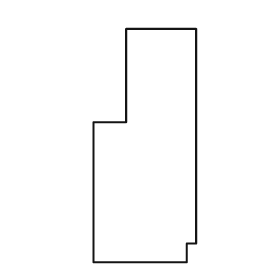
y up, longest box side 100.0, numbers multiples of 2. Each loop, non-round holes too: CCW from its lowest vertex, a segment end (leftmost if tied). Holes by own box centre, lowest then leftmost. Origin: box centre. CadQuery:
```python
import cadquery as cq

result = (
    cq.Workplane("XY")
    .moveTo(-22.0, -50.0)
    .lineTo(18.0, -50.0)
    .lineTo(18.0, -42.0)
    .lineTo(22.0, -42.0)
    .lineTo(22.0, 50.0)
    .lineTo(-8.0, 50.0)
    .lineTo(-8.0, 10.0)
    .lineTo(-22.0, 10.0)
    .close()
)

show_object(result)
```